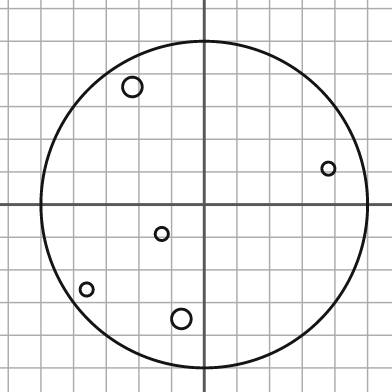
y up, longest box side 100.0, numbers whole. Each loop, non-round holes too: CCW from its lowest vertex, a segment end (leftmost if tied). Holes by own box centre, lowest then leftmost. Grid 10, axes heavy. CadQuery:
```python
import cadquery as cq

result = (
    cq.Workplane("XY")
    .moveTo(0.0, 0.0)
    .circle(50.0)
    .moveTo(-7.0, -35.0)
    .circle(3.0)
    .moveTo(-36.0, -26.0)
    .circle(2.0)
    .moveTo(-13.0, -9.0)
    .circle(2.0)
    .moveTo(38.0, 11.0)
    .circle(2.0)
    .moveTo(-22.0, 36.0)
    .circle(3.0)
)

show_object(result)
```